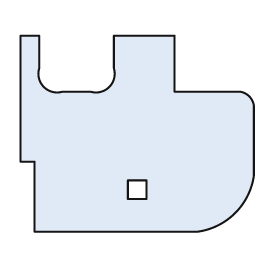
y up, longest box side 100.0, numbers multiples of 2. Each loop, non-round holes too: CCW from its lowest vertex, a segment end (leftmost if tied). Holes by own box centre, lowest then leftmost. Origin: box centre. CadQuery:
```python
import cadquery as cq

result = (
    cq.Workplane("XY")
    .moveTo(-44.0, -42.0)
    .lineTo(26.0, -42.0)
    .threePointArc((42.0, -34.0), (50.0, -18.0))
    .lineTo(50.0, 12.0)
    .threePointArc((48.0, 16.0), (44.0, 18.0))
    .lineTo(16.0, 18.0)
    .lineTo(16.0, 42.0)
    .lineTo(-10.0, 42.0)
    .lineTo(-10.0, 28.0)
    .threePointArc((-12.0, 20.0), (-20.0, 18.0))
    .lineTo(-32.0, 18.0)
    .threePointArc((-40.0, 20.0), (-42.0, 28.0))
    .lineTo(-42.0, 42.0)
    .lineTo(-50.0, 42.0)
    .lineTo(-50.0, -12.0)
    .lineTo(-44.0, -12.0)
    .close()
    .moveTo(-4.0, -28.0)
    .lineTo(4.0, -28.0)
    .lineTo(4.0, -20.0)
    .lineTo(-4.0, -20.0)
    .close()
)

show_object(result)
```